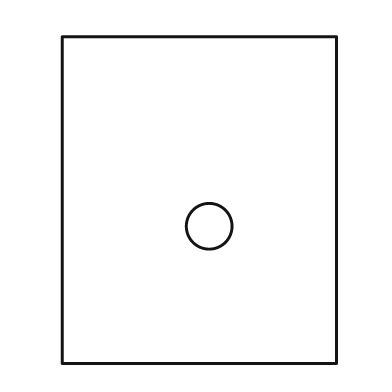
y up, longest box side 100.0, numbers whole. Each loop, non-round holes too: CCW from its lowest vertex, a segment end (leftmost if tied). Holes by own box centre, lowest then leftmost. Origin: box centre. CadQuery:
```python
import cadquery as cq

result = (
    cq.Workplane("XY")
    .moveTo(-42.0, -50.0)
    .lineTo(42.0, -50.0)
    .lineTo(42.0, 50.0)
    .lineTo(-42.0, 50.0)
    .close()
    .moveTo(3.0, -8.0)
    .circle(7.0)
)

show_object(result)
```